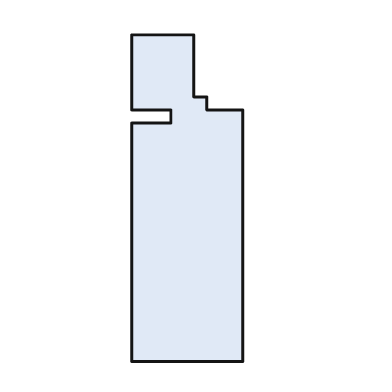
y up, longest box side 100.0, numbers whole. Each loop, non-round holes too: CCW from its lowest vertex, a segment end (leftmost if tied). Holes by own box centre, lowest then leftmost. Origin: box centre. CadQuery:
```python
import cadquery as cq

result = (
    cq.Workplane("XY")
    .moveTo(-17.0, -50.0)
    .lineTo(17.0, -50.0)
    .lineTo(17.0, 27.0)
    .lineTo(6.0, 27.0)
    .lineTo(6.0, 31.0)
    .lineTo(2.0, 31.0)
    .lineTo(2.0, 50.0)
    .lineTo(-17.0, 50.0)
    .lineTo(-17.0, 27.0)
    .lineTo(-5.0, 27.0)
    .lineTo(-5.0, 23.0)
    .lineTo(-17.0, 23.0)
    .close()
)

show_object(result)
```